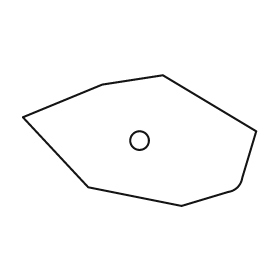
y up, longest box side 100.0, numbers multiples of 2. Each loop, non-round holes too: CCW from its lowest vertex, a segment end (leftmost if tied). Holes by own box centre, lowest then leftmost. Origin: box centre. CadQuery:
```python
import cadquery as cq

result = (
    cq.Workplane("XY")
    .moveTo(18.0, -28.0)
    .lineTo(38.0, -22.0)
    .threePointArc((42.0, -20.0), (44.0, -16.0))
    .lineTo(50.0, 4.0)
    .lineTo(10.0, 28.0)
    .lineTo(-16.0, 24.0)
    .lineTo(-50.0, 10.0)
    .lineTo(-22.0, -20.0)
    .close()
    .moveTo(0.0, 0.0)
    .circle(4.0)
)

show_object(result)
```